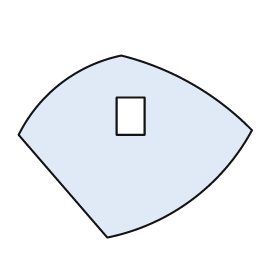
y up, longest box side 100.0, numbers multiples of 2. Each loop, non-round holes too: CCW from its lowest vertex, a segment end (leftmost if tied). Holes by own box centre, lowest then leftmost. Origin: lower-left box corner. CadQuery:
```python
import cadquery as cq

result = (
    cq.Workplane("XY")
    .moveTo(38.0, 0.0)
    .threePointArc((74.0, 16.0), (100.0, 46.0))
    .threePointArc((74.0, 66.0), (44.0, 78.0))
    .threePointArc((18.0, 66.0), (0.0, 44.0))
    .close()
    .moveTo(42.0, 44.0)
    .lineTo(54.0, 44.0)
    .lineTo(54.0, 60.0)
    .lineTo(42.0, 60.0)
    .close()
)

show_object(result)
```